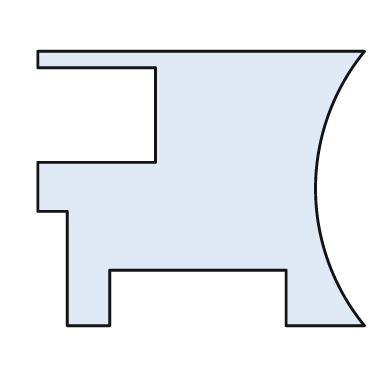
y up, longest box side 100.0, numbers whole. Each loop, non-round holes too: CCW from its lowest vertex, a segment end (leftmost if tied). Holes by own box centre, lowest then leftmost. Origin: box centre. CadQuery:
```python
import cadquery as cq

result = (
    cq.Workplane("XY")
    .moveTo(-41.0, -42.0)
    .lineTo(-28.0, -42.0)
    .lineTo(-28.0, -25.0)
    .lineTo(26.0, -25.0)
    .lineTo(26.0, -42.0)
    .lineTo(50.0, -42.0)
    .threePointArc((35.0, 0.0), (50.0, 42.0))
    .lineTo(-50.0, 42.0)
    .lineTo(-50.0, 37.0)
    .lineTo(-14.0, 37.0)
    .lineTo(-14.0, 8.0)
    .lineTo(-50.0, 8.0)
    .lineTo(-50.0, -7.0)
    .lineTo(-41.0, -7.0)
    .close()
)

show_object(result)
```